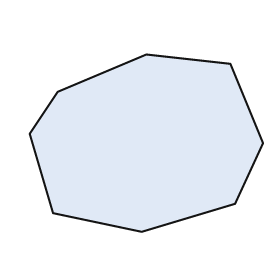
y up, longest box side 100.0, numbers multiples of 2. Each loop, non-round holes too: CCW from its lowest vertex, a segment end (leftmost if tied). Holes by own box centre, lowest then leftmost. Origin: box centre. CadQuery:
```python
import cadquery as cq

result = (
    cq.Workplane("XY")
    .moveTo(-2.0, -38.0)
    .lineTo(38.0, -26.0)
    .lineTo(50.0, 0.0)
    .lineTo(36.0, 34.0)
    .lineTo(0.0, 38.0)
    .lineTo(-38.0, 22.0)
    .lineTo(-50.0, 4.0)
    .lineTo(-40.0, -30.0)
    .close()
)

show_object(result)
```